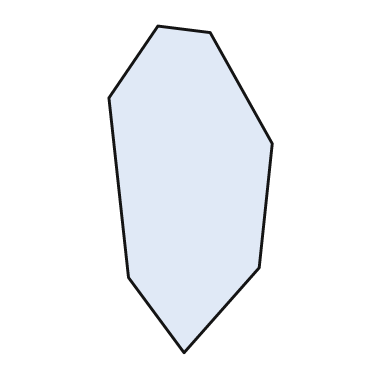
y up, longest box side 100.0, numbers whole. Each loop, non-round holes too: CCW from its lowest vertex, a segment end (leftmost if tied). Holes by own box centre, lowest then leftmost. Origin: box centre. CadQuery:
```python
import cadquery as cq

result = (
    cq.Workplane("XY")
    .moveTo(-2.0, -50.0)
    .lineTo(21.0, -24.0)
    .lineTo(25.0, 14.0)
    .lineTo(6.0, 48.0)
    .lineTo(-10.0, 50.0)
    .lineTo(-25.0, 28.0)
    .lineTo(-19.0, -27.0)
    .close()
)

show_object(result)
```